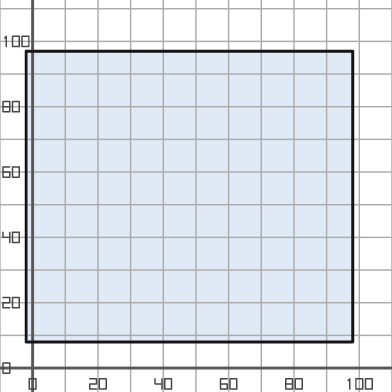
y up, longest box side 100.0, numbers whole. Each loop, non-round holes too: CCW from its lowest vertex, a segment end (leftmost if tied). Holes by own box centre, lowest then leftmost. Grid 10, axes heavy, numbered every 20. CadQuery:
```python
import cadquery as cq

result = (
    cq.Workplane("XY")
    .moveTo(-2.0, 8.0)
    .lineTo(98.0, 8.0)
    .lineTo(98.0, 97.0)
    .lineTo(-2.0, 97.0)
    .close()
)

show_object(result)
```